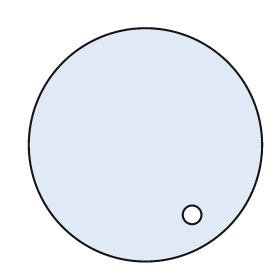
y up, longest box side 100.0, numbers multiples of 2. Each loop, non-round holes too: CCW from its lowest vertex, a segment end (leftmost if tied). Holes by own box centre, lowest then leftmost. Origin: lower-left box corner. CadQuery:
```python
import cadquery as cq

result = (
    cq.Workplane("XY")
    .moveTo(50.0, 50.0)
    .circle(50.0)
    .moveTo(70.0, 20.0)
    .circle(4.0)
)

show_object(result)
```